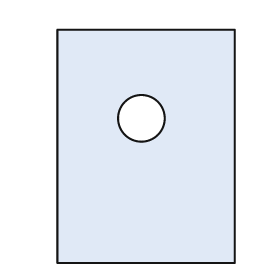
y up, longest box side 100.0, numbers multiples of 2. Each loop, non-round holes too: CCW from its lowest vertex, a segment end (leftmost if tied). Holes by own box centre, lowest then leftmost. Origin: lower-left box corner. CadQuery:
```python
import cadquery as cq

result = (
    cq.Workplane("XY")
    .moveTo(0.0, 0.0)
    .lineTo(76.0, 0.0)
    .lineTo(76.0, 100.0)
    .lineTo(0.0, 100.0)
    .close()
    .moveTo(36.0, 62.0)
    .circle(10.0)
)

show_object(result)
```